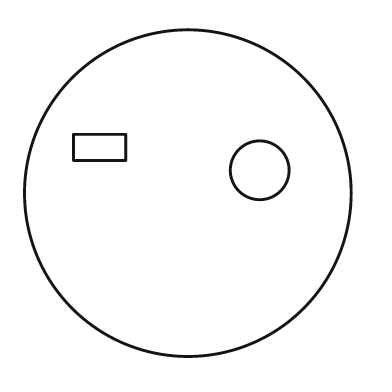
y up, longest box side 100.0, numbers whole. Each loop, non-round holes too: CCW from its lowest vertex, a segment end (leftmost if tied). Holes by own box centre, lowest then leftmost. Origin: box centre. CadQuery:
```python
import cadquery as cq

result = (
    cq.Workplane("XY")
    .moveTo(0.0, 0.0)
    .circle(50.0)
    .moveTo(22.0, 7.0)
    .circle(9.0)
    .moveTo(-35.0, 10.0)
    .lineTo(-19.0, 10.0)
    .lineTo(-19.0, 18.0)
    .lineTo(-35.0, 18.0)
    .close()
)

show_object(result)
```